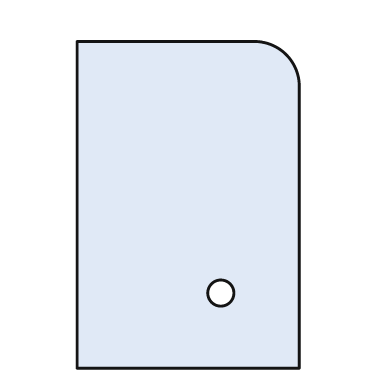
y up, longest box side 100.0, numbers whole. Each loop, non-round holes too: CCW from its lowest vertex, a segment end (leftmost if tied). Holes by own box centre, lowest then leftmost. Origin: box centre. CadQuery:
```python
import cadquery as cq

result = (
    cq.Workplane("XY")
    .moveTo(-34.0, -50.0)
    .lineTo(34.0, -50.0)
    .lineTo(34.0, 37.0)
    .threePointArc((30.0, 46.0), (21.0, 50.0))
    .lineTo(-34.0, 50.0)
    .close()
    .moveTo(10.0, -27.0)
    .circle(4.0)
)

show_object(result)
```